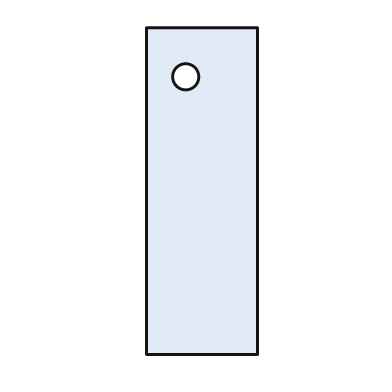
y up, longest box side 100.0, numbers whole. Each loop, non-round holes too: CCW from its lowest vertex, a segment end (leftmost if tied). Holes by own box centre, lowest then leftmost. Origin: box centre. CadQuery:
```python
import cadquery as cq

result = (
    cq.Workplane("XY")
    .moveTo(-17.0, -50.0)
    .lineTo(17.0, -50.0)
    .lineTo(17.0, 50.0)
    .lineTo(-17.0, 50.0)
    .close()
    .moveTo(-5.0, 35.0)
    .circle(4.0)
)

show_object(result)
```